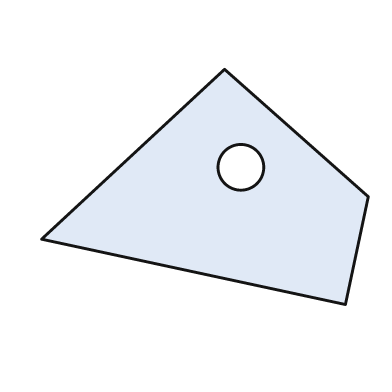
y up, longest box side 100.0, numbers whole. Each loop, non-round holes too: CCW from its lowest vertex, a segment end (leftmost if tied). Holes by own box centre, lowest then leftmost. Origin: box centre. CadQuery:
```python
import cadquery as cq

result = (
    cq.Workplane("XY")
    .moveTo(43.0, -36.0)
    .lineTo(50.0, -3.0)
    .lineTo(6.0, 36.0)
    .lineTo(-50.0, -16.0)
    .close()
    .moveTo(11.0, 6.0)
    .circle(7.0)
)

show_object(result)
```